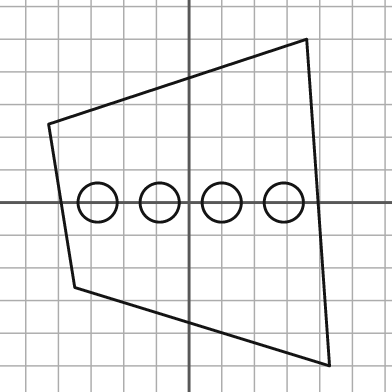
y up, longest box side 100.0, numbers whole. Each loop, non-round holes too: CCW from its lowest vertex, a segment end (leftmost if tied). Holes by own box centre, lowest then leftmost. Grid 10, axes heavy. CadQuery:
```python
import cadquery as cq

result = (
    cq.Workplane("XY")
    .moveTo(43.0, -50.0)
    .lineTo(36.0, 50.0)
    .lineTo(-43.0, 24.0)
    .lineTo(-35.0, -26.0)
    .close()
    .moveTo(-28.0, 0.0)
    .circle(6.0)
    .moveTo(-9.0, 0.0)
    .circle(6.0)
    .moveTo(10.0, 0.0)
    .circle(6.0)
    .moveTo(29.0, 0.0)
    .circle(6.0)
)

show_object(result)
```